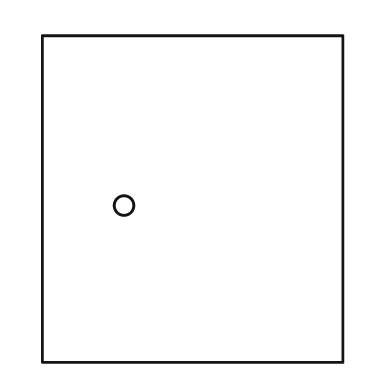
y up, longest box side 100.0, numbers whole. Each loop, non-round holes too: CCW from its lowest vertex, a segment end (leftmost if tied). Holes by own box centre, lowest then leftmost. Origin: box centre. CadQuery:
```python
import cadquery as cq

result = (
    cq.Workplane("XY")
    .moveTo(-46.0, -50.0)
    .lineTo(46.0, -50.0)
    .lineTo(46.0, 50.0)
    .lineTo(-46.0, 50.0)
    .close()
    .moveTo(-21.0, -2.0)
    .circle(3.0)
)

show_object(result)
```